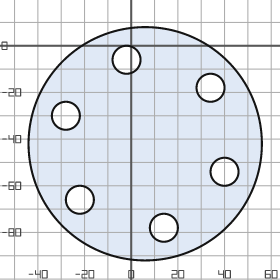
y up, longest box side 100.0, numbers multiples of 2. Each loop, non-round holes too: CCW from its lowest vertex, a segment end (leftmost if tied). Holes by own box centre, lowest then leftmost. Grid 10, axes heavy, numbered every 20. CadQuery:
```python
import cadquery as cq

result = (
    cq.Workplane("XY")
    .moveTo(6.0, -42.0)
    .circle(50.0)
    .moveTo(14.0, -78.0)
    .circle(6.0)
    .moveTo(-22.0, -66.0)
    .circle(6.0)
    .moveTo(40.0, -54.0)
    .circle(6.0)
    .moveTo(-28.0, -30.0)
    .circle(6.0)
    .moveTo(34.0, -18.0)
    .circle(6.0)
    .moveTo(-2.0, -6.0)
    .circle(6.0)
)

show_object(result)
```